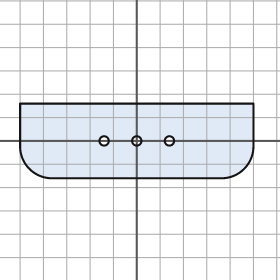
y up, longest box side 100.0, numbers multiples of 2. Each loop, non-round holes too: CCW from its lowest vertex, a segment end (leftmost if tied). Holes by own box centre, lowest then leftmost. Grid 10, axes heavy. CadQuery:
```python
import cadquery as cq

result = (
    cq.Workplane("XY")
    .moveTo(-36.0, -16.0)
    .lineTo(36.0, -16.0)
    .threePointArc((46.0, -12.0), (50.0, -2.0))
    .lineTo(50.0, 16.0)
    .lineTo(-50.0, 16.0)
    .lineTo(-50.0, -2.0)
    .threePointArc((-46.0, -12.0), (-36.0, -16.0))
    .close()
    .moveTo(-14.0, 0.0)
    .circle(2.0)
    .moveTo(0.0, 0.0)
    .circle(2.0)
    .moveTo(14.0, 0.0)
    .circle(2.0)
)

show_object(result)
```